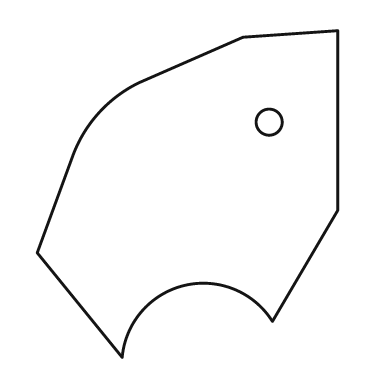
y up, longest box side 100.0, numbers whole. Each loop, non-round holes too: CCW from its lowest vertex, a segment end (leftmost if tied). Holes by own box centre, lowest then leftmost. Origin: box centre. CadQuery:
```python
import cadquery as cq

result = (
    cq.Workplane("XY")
    .moveTo(-20.0, -50.0)
    .threePointArc((-1.0, -28.0), (26.0, -39.0))
    .lineTo(46.0, -5.0)
    .lineTo(46.0, 50.0)
    .lineTo(17.0, 48.0)
    .lineTo(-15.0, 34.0)
    .threePointArc((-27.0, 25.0), (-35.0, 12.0))
    .lineTo(-46.0, -18.0)
    .close()
    .moveTo(25.0, 22.0)
    .circle(4.0)
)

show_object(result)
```